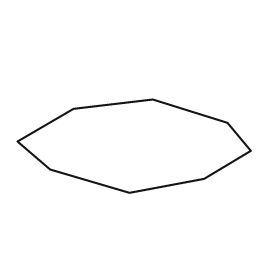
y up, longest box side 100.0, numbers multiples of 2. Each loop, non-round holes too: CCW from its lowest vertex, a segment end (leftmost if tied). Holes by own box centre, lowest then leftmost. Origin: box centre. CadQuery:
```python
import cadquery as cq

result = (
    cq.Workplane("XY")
    .moveTo(-2.0, -20.0)
    .lineTo(30.0, -14.0)
    .lineTo(50.0, -2.0)
    .lineTo(40.0, 10.0)
    .lineTo(8.0, 20.0)
    .lineTo(-26.0, 16.0)
    .lineTo(-50.0, 2.0)
    .lineTo(-36.0, -10.0)
    .close()
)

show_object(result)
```